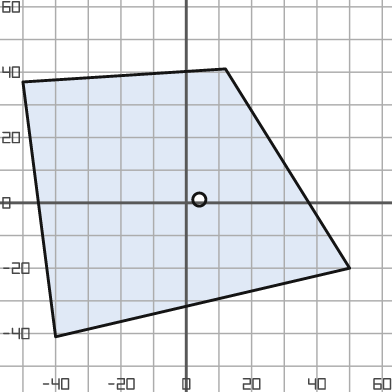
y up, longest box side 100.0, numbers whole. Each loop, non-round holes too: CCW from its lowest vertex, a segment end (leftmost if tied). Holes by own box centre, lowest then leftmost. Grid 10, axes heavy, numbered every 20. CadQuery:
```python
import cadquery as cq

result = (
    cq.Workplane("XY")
    .moveTo(-40.0, -41.0)
    .lineTo(50.0, -20.0)
    .lineTo(12.0, 41.0)
    .lineTo(-50.0, 37.0)
    .close()
    .moveTo(4.0, 1.0)
    .circle(2.0)
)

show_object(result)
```